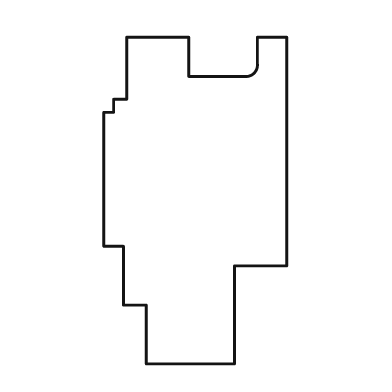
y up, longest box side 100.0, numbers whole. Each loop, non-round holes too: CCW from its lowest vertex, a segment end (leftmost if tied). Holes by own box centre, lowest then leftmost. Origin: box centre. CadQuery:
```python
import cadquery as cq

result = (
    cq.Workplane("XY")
    .moveTo(-15.0, -50.0)
    .lineTo(12.0, -50.0)
    .lineTo(12.0, -20.0)
    .lineTo(28.0, -20.0)
    .lineTo(28.0, 50.0)
    .lineTo(19.0, 50.0)
    .lineTo(19.0, 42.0)
    .threePointArc((18.0, 39.0), (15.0, 38.0))
    .lineTo(-2.0, 38.0)
    .lineTo(-2.0, 50.0)
    .lineTo(-21.0, 50.0)
    .lineTo(-21.0, 31.0)
    .lineTo(-25.0, 31.0)
    .lineTo(-25.0, 27.0)
    .lineTo(-28.0, 27.0)
    .lineTo(-28.0, -14.0)
    .lineTo(-22.0, -14.0)
    .lineTo(-22.0, -32.0)
    .lineTo(-15.0, -32.0)
    .close()
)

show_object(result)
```